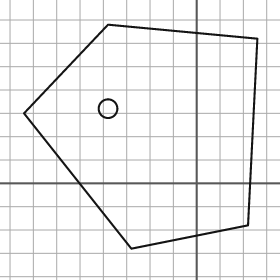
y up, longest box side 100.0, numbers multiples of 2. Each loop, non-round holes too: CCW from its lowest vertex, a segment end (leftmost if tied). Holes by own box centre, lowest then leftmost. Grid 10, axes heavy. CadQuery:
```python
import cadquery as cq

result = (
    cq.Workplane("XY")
    .moveTo(-28.0, -28.0)
    .lineTo(22.0, -18.0)
    .lineTo(26.0, 62.0)
    .lineTo(-38.0, 68.0)
    .lineTo(-74.0, 30.0)
    .close()
    .moveTo(-38.0, 32.0)
    .circle(4.0)
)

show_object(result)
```